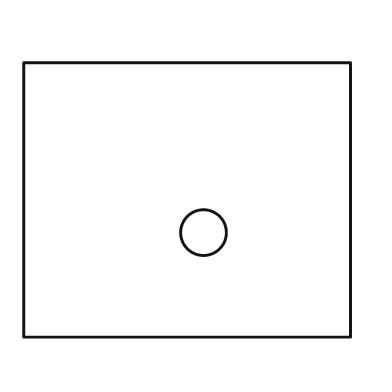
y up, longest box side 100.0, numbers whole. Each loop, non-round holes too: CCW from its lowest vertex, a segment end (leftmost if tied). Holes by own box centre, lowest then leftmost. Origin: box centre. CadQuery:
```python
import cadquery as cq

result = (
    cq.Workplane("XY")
    .moveTo(-50.0, -42.0)
    .lineTo(50.0, -42.0)
    .lineTo(50.0, 42.0)
    .lineTo(-50.0, 42.0)
    .close()
    .moveTo(5.0, -10.0)
    .circle(7.0)
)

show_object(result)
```